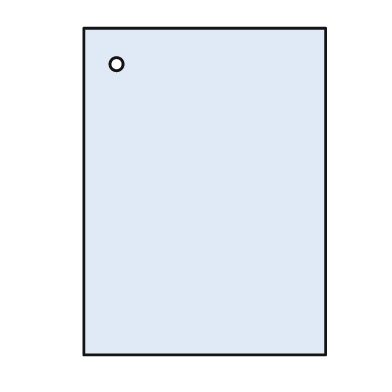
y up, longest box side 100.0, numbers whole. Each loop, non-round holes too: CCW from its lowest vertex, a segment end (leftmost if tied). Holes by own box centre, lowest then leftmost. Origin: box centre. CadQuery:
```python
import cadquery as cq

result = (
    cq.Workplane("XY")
    .moveTo(-37.0, -50.0)
    .lineTo(37.0, -50.0)
    .lineTo(37.0, 50.0)
    .lineTo(-37.0, 50.0)
    .close()
    .moveTo(-27.0, 39.0)
    .circle(2.0)
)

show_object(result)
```